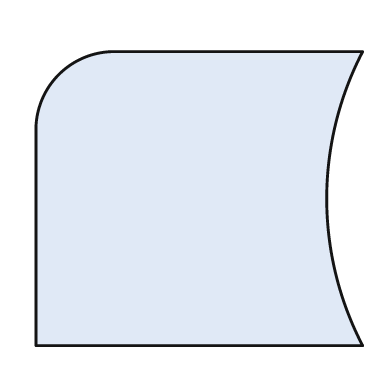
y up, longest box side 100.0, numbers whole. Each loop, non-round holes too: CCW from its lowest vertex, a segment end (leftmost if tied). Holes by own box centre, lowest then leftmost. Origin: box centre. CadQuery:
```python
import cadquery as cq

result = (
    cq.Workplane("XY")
    .moveTo(-50.0, -45.0)
    .lineTo(50.0, -45.0)
    .threePointArc((39.0, 0.0), (50.0, 45.0))
    .lineTo(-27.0, 45.0)
    .threePointArc((-43.0, 38.0), (-50.0, 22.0))
    .close()
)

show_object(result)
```